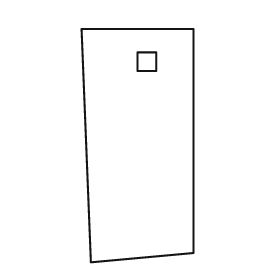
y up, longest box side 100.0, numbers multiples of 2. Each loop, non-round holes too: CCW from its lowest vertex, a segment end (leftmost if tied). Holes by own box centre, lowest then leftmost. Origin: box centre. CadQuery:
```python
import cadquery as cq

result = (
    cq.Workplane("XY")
    .moveTo(-20.0, -50.0)
    .lineTo(24.0, -46.0)
    .lineTo(24.0, 50.0)
    .lineTo(-24.0, 50.0)
    .close()
    .moveTo(0.0, 32.0)
    .lineTo(8.0, 32.0)
    .lineTo(8.0, 40.0)
    .lineTo(0.0, 40.0)
    .close()
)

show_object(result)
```